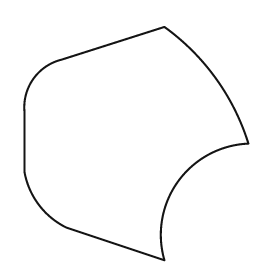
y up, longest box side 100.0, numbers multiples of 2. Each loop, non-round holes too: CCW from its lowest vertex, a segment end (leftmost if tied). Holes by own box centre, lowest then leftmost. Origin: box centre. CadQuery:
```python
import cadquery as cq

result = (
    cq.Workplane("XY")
    .moveTo(12.0, -50.0)
    .threePointArc((18.0, -16.0), (48.0, 0.0))
    .threePointArc((34.0, 28.0), (12.0, 50.0))
    .lineTo(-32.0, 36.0)
    .threePointArc((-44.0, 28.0), (-48.0, 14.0))
    .lineTo(-48.0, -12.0)
    .threePointArc((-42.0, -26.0), (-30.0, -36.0))
    .close()
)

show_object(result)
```